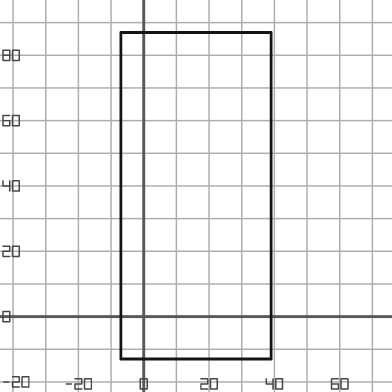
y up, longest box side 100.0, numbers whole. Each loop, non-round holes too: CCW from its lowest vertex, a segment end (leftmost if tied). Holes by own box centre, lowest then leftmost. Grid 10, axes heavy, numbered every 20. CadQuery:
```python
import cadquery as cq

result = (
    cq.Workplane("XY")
    .moveTo(-7.0, -13.0)
    .lineTo(39.0, -13.0)
    .lineTo(39.0, 87.0)
    .lineTo(-7.0, 87.0)
    .close()
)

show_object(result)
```